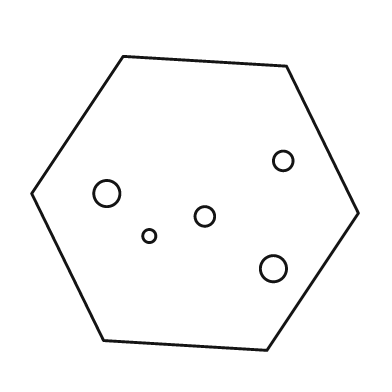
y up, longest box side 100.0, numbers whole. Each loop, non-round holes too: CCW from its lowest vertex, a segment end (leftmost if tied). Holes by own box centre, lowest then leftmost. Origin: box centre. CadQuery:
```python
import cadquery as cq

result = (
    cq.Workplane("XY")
    .moveTo(22.0, -45.0)
    .lineTo(50.0, -3.0)
    .lineTo(28.0, 42.0)
    .lineTo(-22.0, 45.0)
    .lineTo(-50.0, 3.0)
    .lineTo(-28.0, -42.0)
    .close()
    .moveTo(24.0, -20.0)
    .circle(4.0)
    .moveTo(-14.0, -10.0)
    .circle(2.0)
    .moveTo(3.0, -4.0)
    .circle(3.0)
    .moveTo(-27.0, 3.0)
    .circle(4.0)
    .moveTo(27.0, 13.0)
    .circle(3.0)
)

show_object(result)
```